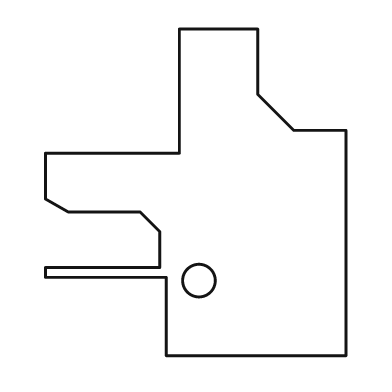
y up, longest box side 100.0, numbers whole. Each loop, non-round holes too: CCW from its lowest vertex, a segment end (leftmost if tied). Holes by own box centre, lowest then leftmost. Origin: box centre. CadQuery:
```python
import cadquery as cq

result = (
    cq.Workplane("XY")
    .moveTo(-9.0, -50.0)
    .lineTo(46.0, -50.0)
    .lineTo(46.0, 19.0)
    .lineTo(30.0, 19.0)
    .lineTo(19.0, 30.0)
    .lineTo(19.0, 50.0)
    .lineTo(-5.0, 50.0)
    .lineTo(-5.0, 12.0)
    .lineTo(-46.0, 12.0)
    .lineTo(-46.0, -2.0)
    .lineTo(-39.0, -6.0)
    .lineTo(-17.0, -6.0)
    .lineTo(-11.0, -12.0)
    .lineTo(-11.0, -23.0)
    .lineTo(-46.0, -23.0)
    .lineTo(-46.0, -26.0)
    .lineTo(-9.0, -26.0)
    .close()
    .moveTo(1.0, -27.0)
    .circle(5.0)
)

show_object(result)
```